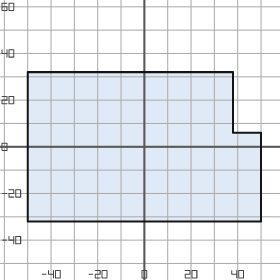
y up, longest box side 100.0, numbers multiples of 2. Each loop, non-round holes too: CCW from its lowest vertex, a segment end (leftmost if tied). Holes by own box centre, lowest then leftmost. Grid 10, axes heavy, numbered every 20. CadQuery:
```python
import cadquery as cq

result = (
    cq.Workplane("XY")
    .moveTo(-50.0, -32.0)
    .lineTo(50.0, -32.0)
    .lineTo(50.0, 6.0)
    .lineTo(38.0, 6.0)
    .lineTo(38.0, 32.0)
    .lineTo(-50.0, 32.0)
    .close()
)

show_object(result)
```